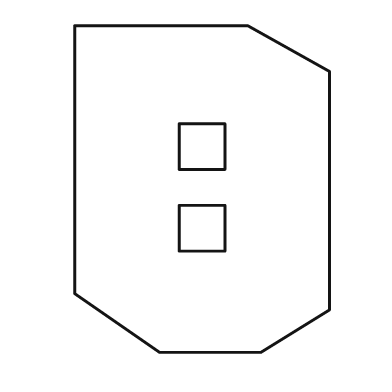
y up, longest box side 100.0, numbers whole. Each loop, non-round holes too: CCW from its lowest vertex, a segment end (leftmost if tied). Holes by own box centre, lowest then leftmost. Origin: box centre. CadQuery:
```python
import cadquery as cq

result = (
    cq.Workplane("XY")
    .moveTo(-13.0, -50.0)
    .lineTo(18.0, -50.0)
    .lineTo(39.0, -37.0)
    .lineTo(39.0, 36.0)
    .lineTo(14.0, 50.0)
    .lineTo(-39.0, 50.0)
    .lineTo(-39.0, -32.0)
    .close()
    .moveTo(-7.0, -19.0)
    .lineTo(7.0, -19.0)
    .lineTo(7.0, -5.0)
    .lineTo(-7.0, -5.0)
    .close()
    .moveTo(-7.0, 6.0)
    .lineTo(7.0, 6.0)
    .lineTo(7.0, 20.0)
    .lineTo(-7.0, 20.0)
    .close()
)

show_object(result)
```